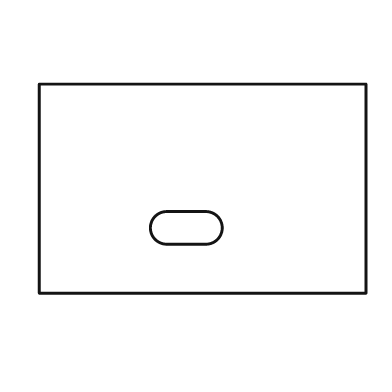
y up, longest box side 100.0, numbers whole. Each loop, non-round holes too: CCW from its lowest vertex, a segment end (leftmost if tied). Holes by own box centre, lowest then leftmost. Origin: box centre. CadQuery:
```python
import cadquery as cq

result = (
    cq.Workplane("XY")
    .moveTo(-50.0, -32.0)
    .lineTo(50.0, -32.0)
    .lineTo(50.0, 32.0)
    .lineTo(-50.0, 32.0)
    .close()
    .moveTo(-11.0, -17.0)
    .lineTo(1.0, -17.0)
    .threePointArc((6.0, -12.0), (1.0, -7.0))
    .lineTo(-11.0, -7.0)
    .threePointArc((-16.0, -12.0), (-11.0, -17.0))
    .close()
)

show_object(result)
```